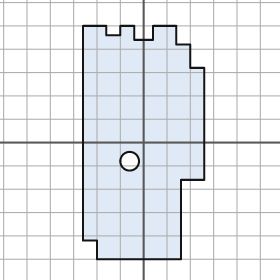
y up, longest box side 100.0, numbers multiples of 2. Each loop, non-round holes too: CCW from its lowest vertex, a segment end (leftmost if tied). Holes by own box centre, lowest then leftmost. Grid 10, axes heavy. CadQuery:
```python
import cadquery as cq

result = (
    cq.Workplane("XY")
    .moveTo(-20.0, -50.0)
    .lineTo(16.0, -50.0)
    .lineTo(16.0, -16.0)
    .lineTo(26.0, -16.0)
    .lineTo(26.0, 32.0)
    .lineTo(20.0, 32.0)
    .lineTo(20.0, 42.0)
    .lineTo(14.0, 42.0)
    .lineTo(14.0, 50.0)
    .lineTo(4.0, 50.0)
    .lineTo(4.0, 44.0)
    .lineTo(-4.0, 44.0)
    .lineTo(-4.0, 50.0)
    .lineTo(-10.0, 50.0)
    .lineTo(-10.0, 46.0)
    .lineTo(-16.0, 46.0)
    .lineTo(-16.0, 50.0)
    .lineTo(-26.0, 50.0)
    .lineTo(-26.0, -42.0)
    .lineTo(-20.0, -42.0)
    .close()
    .moveTo(-6.0, -8.0)
    .circle(4.0)
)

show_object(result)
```